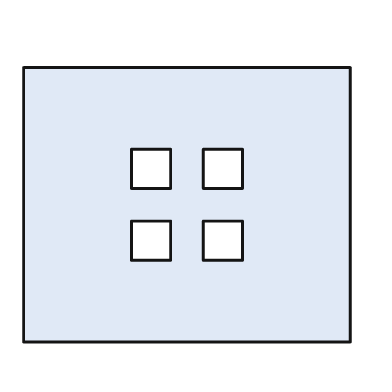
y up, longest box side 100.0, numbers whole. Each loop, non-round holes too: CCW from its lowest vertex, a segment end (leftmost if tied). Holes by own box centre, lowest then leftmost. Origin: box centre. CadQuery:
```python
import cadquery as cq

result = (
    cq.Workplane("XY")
    .moveTo(-50.0, -42.0)
    .lineTo(50.0, -42.0)
    .lineTo(50.0, 42.0)
    .lineTo(-50.0, 42.0)
    .close()
    .moveTo(-17.0, -17.0)
    .lineTo(-5.0, -17.0)
    .lineTo(-5.0, -5.0)
    .lineTo(-17.0, -5.0)
    .close()
    .moveTo(5.0, -17.0)
    .lineTo(17.0, -17.0)
    .lineTo(17.0, -5.0)
    .lineTo(5.0, -5.0)
    .close()
    .moveTo(-17.0, 5.0)
    .lineTo(-5.0, 5.0)
    .lineTo(-5.0, 17.0)
    .lineTo(-17.0, 17.0)
    .close()
    .moveTo(5.0, 5.0)
    .lineTo(17.0, 5.0)
    .lineTo(17.0, 17.0)
    .lineTo(5.0, 17.0)
    .close()
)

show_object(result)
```